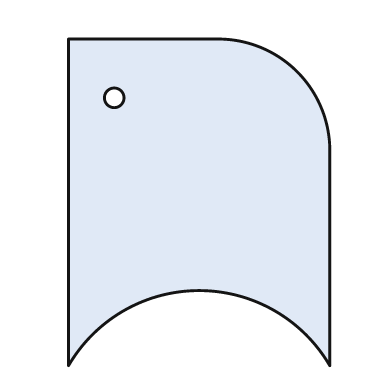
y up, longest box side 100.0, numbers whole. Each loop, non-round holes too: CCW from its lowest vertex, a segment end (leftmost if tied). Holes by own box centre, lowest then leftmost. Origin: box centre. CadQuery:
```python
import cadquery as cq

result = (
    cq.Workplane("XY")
    .moveTo(-40.0, -50.0)
    .threePointArc((0.0, -27.0), (40.0, -50.0))
    .lineTo(40.0, 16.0)
    .threePointArc((30.0, 40.0), (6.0, 50.0))
    .lineTo(-40.0, 50.0)
    .close()
    .moveTo(-26.0, 32.0)
    .circle(3.0)
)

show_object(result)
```